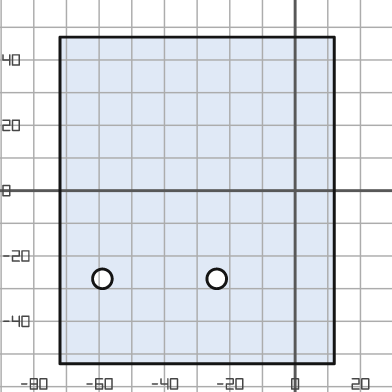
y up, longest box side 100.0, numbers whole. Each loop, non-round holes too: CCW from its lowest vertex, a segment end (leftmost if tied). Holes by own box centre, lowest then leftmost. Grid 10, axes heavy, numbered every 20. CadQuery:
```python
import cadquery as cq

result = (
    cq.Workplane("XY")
    .moveTo(-72.0, -53.0)
    .lineTo(12.0, -53.0)
    .lineTo(12.0, 47.0)
    .lineTo(-72.0, 47.0)
    .close()
    .moveTo(-59.0, -27.0)
    .circle(3.0)
    .moveTo(-24.0, -27.0)
    .circle(3.0)
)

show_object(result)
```